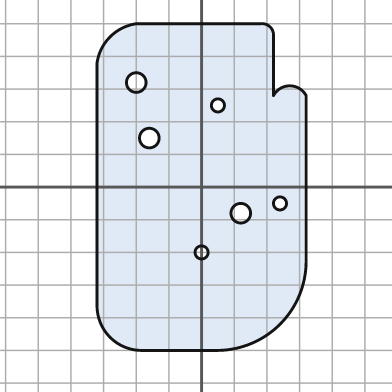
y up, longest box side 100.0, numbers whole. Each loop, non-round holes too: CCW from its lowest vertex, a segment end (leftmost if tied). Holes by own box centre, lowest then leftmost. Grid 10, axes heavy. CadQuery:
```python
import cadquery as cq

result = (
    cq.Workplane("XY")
    .moveTo(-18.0, -50.0)
    .lineTo(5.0, -50.0)
    .threePointArc((24.0, -42.0), (32.0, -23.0))
    .lineTo(32.0, 28.0)
    .threePointArc((27.0, 31.0), (22.0, 28.0))
    .lineTo(22.0, 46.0)
    .threePointArc((21.0, 49.0), (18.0, 50.0))
    .lineTo(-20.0, 50.0)
    .threePointArc((-28.0, 46.0), (-32.0, 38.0))
    .lineTo(-32.0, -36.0)
    .threePointArc((-28.0, -46.0), (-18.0, -50.0))
    .close()
    .moveTo(0.0, -20.0)
    .circle(2.0)
    .moveTo(12.0, -8.0)
    .circle(3.0)
    .moveTo(24.0, -5.0)
    .circle(2.0)
    .moveTo(-16.0, 15.0)
    .circle(3.0)
    .moveTo(5.0, 25.0)
    .circle(2.0)
    .moveTo(-20.0, 32.0)
    .circle(3.0)
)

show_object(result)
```